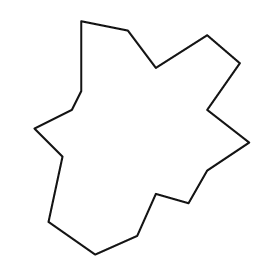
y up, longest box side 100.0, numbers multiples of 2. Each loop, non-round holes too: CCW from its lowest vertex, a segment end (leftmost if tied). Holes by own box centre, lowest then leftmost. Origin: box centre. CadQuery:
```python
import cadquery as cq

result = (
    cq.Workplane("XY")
    .moveTo(-20.0, -50.0)
    .lineTo(-2.0, -42.0)
    .lineTo(6.0, -24.0)
    .lineTo(20.0, -28.0)
    .lineTo(28.0, -14.0)
    .lineTo(46.0, -2.0)
    .lineTo(28.0, 12.0)
    .lineTo(42.0, 32.0)
    .lineTo(28.0, 44.0)
    .lineTo(6.0, 30.0)
    .lineTo(-6.0, 46.0)
    .lineTo(-26.0, 50.0)
    .lineTo(-26.0, 20.0)
    .lineTo(-30.0, 12.0)
    .lineTo(-46.0, 4.0)
    .lineTo(-34.0, -8.0)
    .lineTo(-40.0, -36.0)
    .close()
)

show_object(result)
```